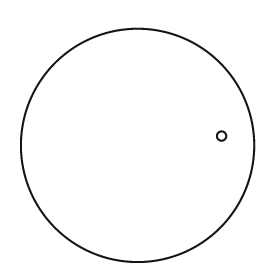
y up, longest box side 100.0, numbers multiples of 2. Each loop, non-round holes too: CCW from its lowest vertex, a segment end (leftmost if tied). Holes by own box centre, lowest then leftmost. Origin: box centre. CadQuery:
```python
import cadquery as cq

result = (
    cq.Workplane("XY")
    .moveTo(0.0, 0.0)
    .circle(50.0)
    .moveTo(36.0, 4.0)
    .circle(2.0)
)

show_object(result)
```